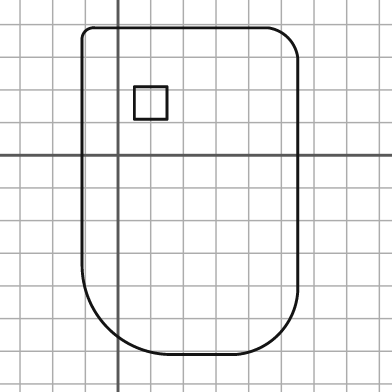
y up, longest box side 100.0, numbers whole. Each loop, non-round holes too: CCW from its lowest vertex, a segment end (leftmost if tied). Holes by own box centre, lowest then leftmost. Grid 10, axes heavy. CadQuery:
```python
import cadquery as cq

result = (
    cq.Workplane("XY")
    .moveTo(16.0, -61.0)
    .lineTo(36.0, -61.0)
    .threePointArc((49.0, -55.0), (55.0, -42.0))
    .lineTo(55.0, 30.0)
    .threePointArc((52.0, 36.0), (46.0, 39.0))
    .lineTo(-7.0, 39.0)
    .threePointArc((-10.0, 38.0), (-11.0, 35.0))
    .lineTo(-11.0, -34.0)
    .threePointArc((-3.0, -53.0), (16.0, -61.0))
    .close()
    .moveTo(5.0, 11.0)
    .lineTo(15.0, 11.0)
    .lineTo(15.0, 21.0)
    .lineTo(5.0, 21.0)
    .close()
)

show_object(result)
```